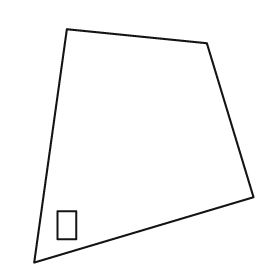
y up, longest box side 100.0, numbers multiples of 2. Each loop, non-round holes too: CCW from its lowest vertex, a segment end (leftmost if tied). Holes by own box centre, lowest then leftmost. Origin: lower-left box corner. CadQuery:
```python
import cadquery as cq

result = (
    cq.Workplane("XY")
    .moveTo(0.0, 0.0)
    .lineTo(94.0, 28.0)
    .lineTo(74.0, 94.0)
    .lineTo(14.0, 100.0)
    .close()
    .moveTo(10.0, 10.0)
    .lineTo(18.0, 10.0)
    .lineTo(18.0, 22.0)
    .lineTo(10.0, 22.0)
    .close()
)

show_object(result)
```